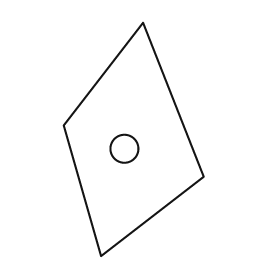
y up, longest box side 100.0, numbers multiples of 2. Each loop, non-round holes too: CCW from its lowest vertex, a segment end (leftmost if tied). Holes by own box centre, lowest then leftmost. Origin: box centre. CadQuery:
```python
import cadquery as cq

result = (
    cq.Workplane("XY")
    .moveTo(-14.0, -50.0)
    .lineTo(30.0, -16.0)
    .lineTo(4.0, 50.0)
    .lineTo(-30.0, 6.0)
    .close()
    .moveTo(-4.0, -4.0)
    .circle(6.0)
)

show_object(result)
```